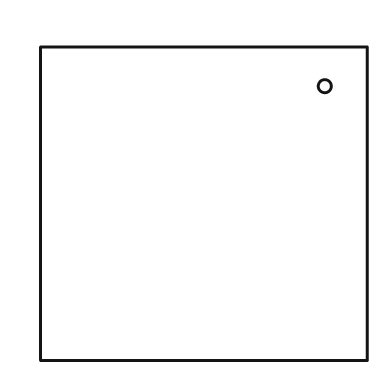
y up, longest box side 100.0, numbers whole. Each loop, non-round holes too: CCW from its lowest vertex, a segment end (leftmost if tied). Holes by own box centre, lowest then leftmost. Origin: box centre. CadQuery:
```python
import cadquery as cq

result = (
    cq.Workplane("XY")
    .moveTo(-50.0, -48.0)
    .lineTo(50.0, -48.0)
    .lineTo(50.0, 48.0)
    .lineTo(-50.0, 48.0)
    .close()
    .moveTo(37.0, 36.0)
    .circle(2.0)
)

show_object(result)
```